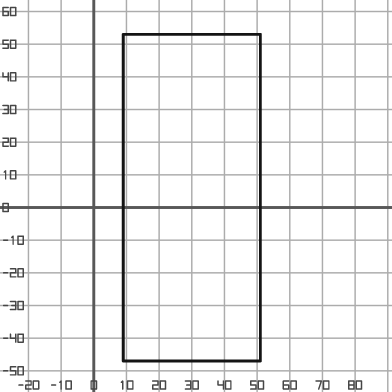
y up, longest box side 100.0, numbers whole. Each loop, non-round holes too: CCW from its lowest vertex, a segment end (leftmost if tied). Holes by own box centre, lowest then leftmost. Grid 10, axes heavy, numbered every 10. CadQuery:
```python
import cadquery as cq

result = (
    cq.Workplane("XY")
    .moveTo(9.0, -47.0)
    .lineTo(51.0, -47.0)
    .lineTo(51.0, 53.0)
    .lineTo(9.0, 53.0)
    .close()
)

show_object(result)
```